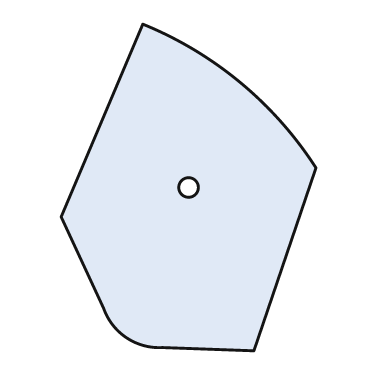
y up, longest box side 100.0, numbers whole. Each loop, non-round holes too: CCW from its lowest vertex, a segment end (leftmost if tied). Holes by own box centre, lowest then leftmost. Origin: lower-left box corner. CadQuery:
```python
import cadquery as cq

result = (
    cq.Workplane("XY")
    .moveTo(59.0, 0.0)
    .lineTo(78.0, 56.0)
    .threePointArc((55.0, 82.0), (25.0, 100.0))
    .lineTo(0.0, 41.0)
    .lineTo(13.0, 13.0)
    .threePointArc((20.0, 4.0), (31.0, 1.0))
    .close()
    .moveTo(39.0, 50.0)
    .circle(3.0)
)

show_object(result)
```